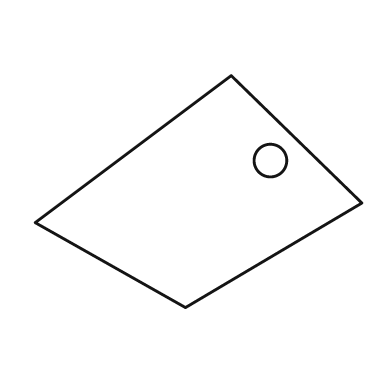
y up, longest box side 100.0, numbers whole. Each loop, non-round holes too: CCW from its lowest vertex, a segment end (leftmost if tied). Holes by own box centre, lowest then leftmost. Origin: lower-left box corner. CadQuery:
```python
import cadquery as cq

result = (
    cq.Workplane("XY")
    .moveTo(46.0, 0.0)
    .lineTo(100.0, 32.0)
    .lineTo(60.0, 71.0)
    .lineTo(0.0, 26.0)
    .close()
    .moveTo(72.0, 45.0)
    .circle(5.0)
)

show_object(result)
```